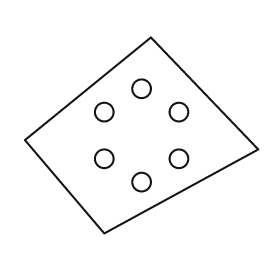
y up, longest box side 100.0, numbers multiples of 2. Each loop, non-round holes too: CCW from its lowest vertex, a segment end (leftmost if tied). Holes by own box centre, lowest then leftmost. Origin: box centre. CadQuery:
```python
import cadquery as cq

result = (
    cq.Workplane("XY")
    .moveTo(-16.0, -42.0)
    .lineTo(50.0, -6.0)
    .lineTo(4.0, 42.0)
    .lineTo(-50.0, -2.0)
    .close()
    .moveTo(0.0, -20.0)
    .circle(4.0)
    .moveTo(-16.0, -10.0)
    .circle(4.0)
    .moveTo(16.0, -10.0)
    .circle(4.0)
    .moveTo(-16.0, 10.0)
    .circle(4.0)
    .moveTo(16.0, 10.0)
    .circle(4.0)
    .moveTo(0.0, 20.0)
    .circle(4.0)
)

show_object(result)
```